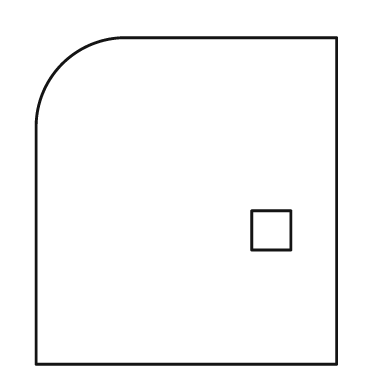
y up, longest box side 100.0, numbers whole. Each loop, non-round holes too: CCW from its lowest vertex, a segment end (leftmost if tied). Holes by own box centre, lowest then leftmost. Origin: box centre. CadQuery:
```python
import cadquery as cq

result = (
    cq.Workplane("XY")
    .moveTo(-46.0, -50.0)
    .lineTo(46.0, -50.0)
    .lineTo(46.0, 50.0)
    .lineTo(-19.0, 50.0)
    .threePointArc((-38.0, 42.0), (-46.0, 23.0))
    .close()
    .moveTo(20.0, -15.0)
    .lineTo(32.0, -15.0)
    .lineTo(32.0, -3.0)
    .lineTo(20.0, -3.0)
    .close()
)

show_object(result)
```